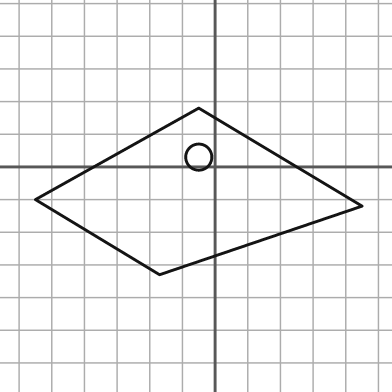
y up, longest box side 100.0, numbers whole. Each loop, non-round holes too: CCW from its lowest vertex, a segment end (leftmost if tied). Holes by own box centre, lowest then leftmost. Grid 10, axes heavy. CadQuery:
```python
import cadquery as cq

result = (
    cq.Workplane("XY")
    .moveTo(-17.0, -33.0)
    .lineTo(45.0, -12.0)
    .lineTo(-5.0, 18.0)
    .lineTo(-55.0, -10.0)
    .close()
    .moveTo(-5.0, 3.0)
    .circle(4.0)
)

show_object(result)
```